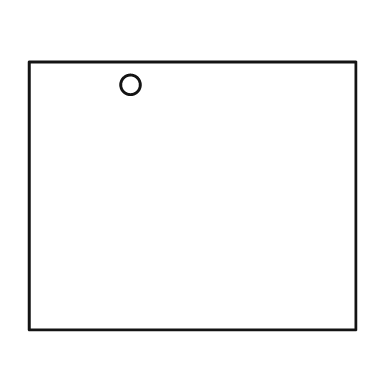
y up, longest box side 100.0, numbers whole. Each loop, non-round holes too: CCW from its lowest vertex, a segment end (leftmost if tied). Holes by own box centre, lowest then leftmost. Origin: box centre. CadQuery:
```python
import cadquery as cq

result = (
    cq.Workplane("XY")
    .moveTo(-50.0, -41.0)
    .lineTo(50.0, -41.0)
    .lineTo(50.0, 41.0)
    .lineTo(-50.0, 41.0)
    .close()
    .moveTo(-19.0, 34.0)
    .circle(3.0)
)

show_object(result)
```